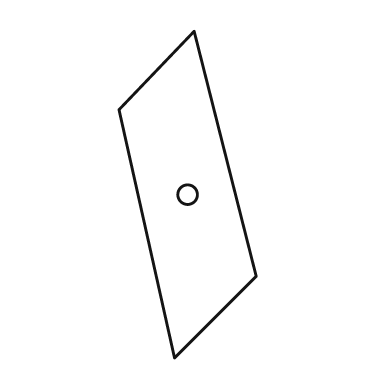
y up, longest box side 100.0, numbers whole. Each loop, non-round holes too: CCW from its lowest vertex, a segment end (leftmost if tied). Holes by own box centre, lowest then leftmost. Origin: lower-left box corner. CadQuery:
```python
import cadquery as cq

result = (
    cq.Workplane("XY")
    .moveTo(17.0, 0.0)
    .lineTo(42.0, 25.0)
    .lineTo(23.0, 100.0)
    .lineTo(0.0, 76.0)
    .close()
    .moveTo(21.0, 50.0)
    .circle(3.0)
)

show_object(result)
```